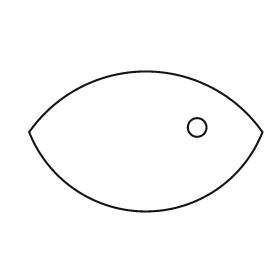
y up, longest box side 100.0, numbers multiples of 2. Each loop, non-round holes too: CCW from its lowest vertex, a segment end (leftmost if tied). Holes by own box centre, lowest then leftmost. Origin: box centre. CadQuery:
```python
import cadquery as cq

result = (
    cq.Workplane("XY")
    .moveTo(-50.0, 4.0)
    .threePointArc((0.0, -30.0), (50.0, 4.0))
    .threePointArc((0.0, 30.0), (-50.0, 4.0))
    .close()
    .moveTo(22.0, 6.0)
    .circle(4.0)
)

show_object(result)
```